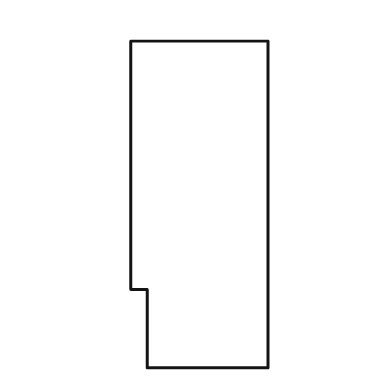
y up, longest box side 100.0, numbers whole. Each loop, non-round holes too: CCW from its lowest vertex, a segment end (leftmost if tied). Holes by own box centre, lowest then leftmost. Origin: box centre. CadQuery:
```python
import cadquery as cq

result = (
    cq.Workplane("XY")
    .moveTo(-16.0, -50.0)
    .lineTo(21.0, -50.0)
    .lineTo(21.0, 50.0)
    .lineTo(-21.0, 50.0)
    .lineTo(-21.0, -26.0)
    .lineTo(-16.0, -26.0)
    .close()
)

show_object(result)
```